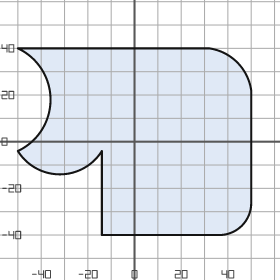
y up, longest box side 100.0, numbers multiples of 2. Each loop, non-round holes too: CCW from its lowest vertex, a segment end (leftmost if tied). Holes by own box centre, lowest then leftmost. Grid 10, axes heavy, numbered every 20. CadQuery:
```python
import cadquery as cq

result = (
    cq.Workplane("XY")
    .moveTo(-14.0, -40.0)
    .lineTo(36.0, -40.0)
    .threePointArc((46.0, -36.0), (50.0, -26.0))
    .lineTo(50.0, 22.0)
    .threePointArc((44.0, 34.0), (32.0, 40.0))
    .lineTo(-50.0, 40.0)
    .threePointArc((-36.0, 18.0), (-50.0, -4.0))
    .threePointArc((-32.0, -14.0), (-14.0, -4.0))
    .close()
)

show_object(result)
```